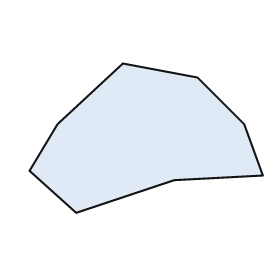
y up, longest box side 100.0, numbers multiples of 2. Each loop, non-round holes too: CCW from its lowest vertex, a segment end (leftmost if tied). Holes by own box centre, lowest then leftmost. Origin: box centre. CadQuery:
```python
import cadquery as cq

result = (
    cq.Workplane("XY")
    .moveTo(-30.0, -32.0)
    .lineTo(12.0, -18.0)
    .lineTo(50.0, -16.0)
    .lineTo(42.0, 6.0)
    .lineTo(22.0, 26.0)
    .lineTo(-10.0, 32.0)
    .lineTo(-38.0, 6.0)
    .lineTo(-50.0, -14.0)
    .close()
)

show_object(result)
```